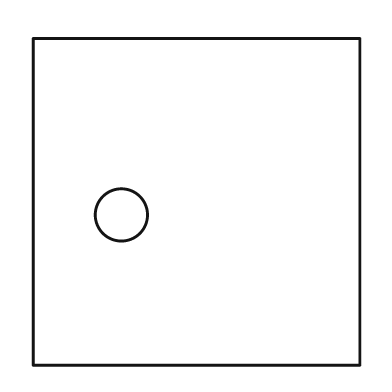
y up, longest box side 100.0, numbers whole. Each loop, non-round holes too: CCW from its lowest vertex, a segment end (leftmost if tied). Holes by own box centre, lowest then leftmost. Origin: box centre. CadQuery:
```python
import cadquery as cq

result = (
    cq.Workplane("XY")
    .moveTo(-50.0, -50.0)
    .lineTo(50.0, -50.0)
    .lineTo(50.0, 50.0)
    .lineTo(-50.0, 50.0)
    .close()
    .moveTo(-23.0, -4.0)
    .circle(8.0)
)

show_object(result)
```